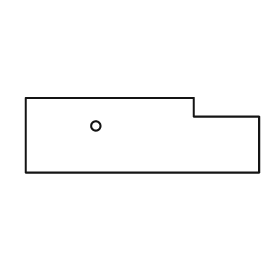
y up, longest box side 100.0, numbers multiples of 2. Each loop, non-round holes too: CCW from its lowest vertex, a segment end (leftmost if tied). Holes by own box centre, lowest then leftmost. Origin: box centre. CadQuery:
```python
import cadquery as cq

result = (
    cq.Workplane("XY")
    .moveTo(-50.0, -16.0)
    .lineTo(50.0, -16.0)
    .lineTo(50.0, 8.0)
    .lineTo(22.0, 8.0)
    .lineTo(22.0, 16.0)
    .lineTo(-50.0, 16.0)
    .close()
    .moveTo(-20.0, 4.0)
    .circle(2.0)
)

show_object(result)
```